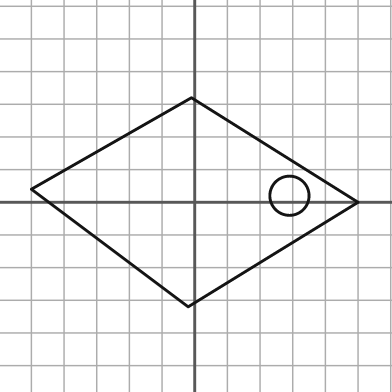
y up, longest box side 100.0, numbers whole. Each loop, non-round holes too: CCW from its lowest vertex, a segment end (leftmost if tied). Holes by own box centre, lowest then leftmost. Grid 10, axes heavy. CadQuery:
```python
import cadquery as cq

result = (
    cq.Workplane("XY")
    .moveTo(-2.0, -32.0)
    .lineTo(50.0, 0.0)
    .lineTo(-1.0, 32.0)
    .lineTo(-50.0, 4.0)
    .close()
    .moveTo(29.0, 2.0)
    .circle(6.0)
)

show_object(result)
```